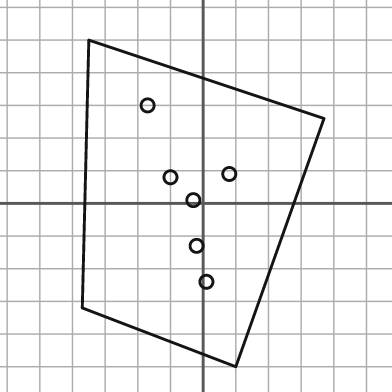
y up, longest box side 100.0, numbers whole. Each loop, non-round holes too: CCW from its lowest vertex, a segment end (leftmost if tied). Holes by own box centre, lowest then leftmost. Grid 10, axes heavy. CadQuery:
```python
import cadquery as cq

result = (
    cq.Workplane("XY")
    .moveTo(10.0, -50.0)
    .lineTo(37.0, 26.0)
    .lineTo(-35.0, 50.0)
    .lineTo(-37.0, -32.0)
    .close()
    .moveTo(1.0, -24.0)
    .circle(2.0)
    .moveTo(-2.0, -13.0)
    .circle(2.0)
    .moveTo(-3.0, 1.0)
    .circle(2.0)
    .moveTo(-10.0, 8.0)
    .circle(2.0)
    .moveTo(8.0, 9.0)
    .circle(2.0)
    .moveTo(-17.0, 30.0)
    .circle(2.0)
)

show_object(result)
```